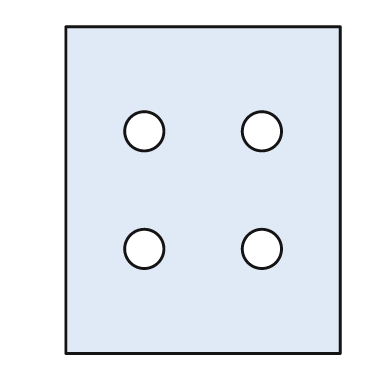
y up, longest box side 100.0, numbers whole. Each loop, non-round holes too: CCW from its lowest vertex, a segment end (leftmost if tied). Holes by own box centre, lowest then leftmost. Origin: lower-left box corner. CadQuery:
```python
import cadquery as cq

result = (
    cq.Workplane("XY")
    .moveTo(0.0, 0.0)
    .lineTo(84.0, 0.0)
    .lineTo(84.0, 100.0)
    .lineTo(0.0, 100.0)
    .close()
    .moveTo(24.0, 32.0)
    .circle(6.0)
    .moveTo(60.0, 32.0)
    .circle(6.0)
    .moveTo(24.0, 68.0)
    .circle(6.0)
    .moveTo(60.0, 68.0)
    .circle(6.0)
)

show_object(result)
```